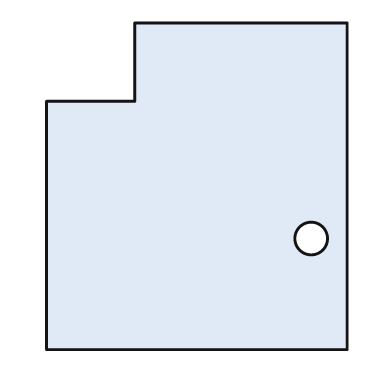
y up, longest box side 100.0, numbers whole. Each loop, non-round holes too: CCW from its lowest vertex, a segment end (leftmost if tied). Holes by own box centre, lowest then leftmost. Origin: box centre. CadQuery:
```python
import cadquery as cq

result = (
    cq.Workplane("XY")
    .moveTo(-46.0, -50.0)
    .lineTo(46.0, -50.0)
    .lineTo(46.0, 50.0)
    .lineTo(-19.0, 50.0)
    .lineTo(-19.0, 26.0)
    .lineTo(-46.0, 26.0)
    .close()
    .moveTo(35.0, -16.0)
    .circle(5.0)
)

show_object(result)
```